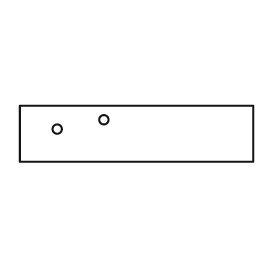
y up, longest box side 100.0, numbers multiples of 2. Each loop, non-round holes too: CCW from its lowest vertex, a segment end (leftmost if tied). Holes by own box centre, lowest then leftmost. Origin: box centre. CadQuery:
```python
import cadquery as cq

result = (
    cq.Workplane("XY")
    .moveTo(-50.0, -12.0)
    .lineTo(50.0, -12.0)
    .lineTo(50.0, 12.0)
    .lineTo(-50.0, 12.0)
    .close()
    .moveTo(-34.0, 2.0)
    .circle(2.0)
    .moveTo(-14.0, 6.0)
    .circle(2.0)
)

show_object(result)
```